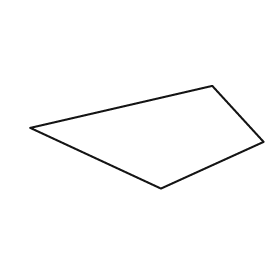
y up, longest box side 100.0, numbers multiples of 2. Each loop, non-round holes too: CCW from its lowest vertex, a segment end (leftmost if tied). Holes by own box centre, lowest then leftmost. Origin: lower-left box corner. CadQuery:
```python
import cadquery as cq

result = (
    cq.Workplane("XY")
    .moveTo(56.0, 0.0)
    .lineTo(100.0, 20.0)
    .lineTo(78.0, 44.0)
    .lineTo(0.0, 26.0)
    .close()
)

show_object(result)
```